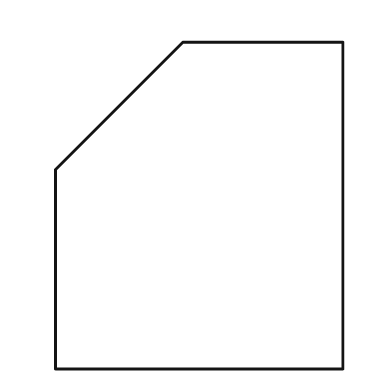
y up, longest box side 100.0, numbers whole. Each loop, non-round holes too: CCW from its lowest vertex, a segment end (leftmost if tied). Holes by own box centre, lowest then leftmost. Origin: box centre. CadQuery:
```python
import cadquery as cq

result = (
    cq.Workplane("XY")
    .moveTo(-44.0, -50.0)
    .lineTo(44.0, -50.0)
    .lineTo(44.0, 50.0)
    .lineTo(-5.0, 50.0)
    .lineTo(-44.0, 11.0)
    .close()
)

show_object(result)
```